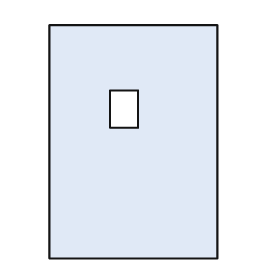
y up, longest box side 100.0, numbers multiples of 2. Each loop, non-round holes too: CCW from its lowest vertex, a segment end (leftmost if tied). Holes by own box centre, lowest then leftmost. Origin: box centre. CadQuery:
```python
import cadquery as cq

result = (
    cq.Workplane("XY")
    .moveTo(-36.0, -50.0)
    .lineTo(36.0, -50.0)
    .lineTo(36.0, 50.0)
    .lineTo(-36.0, 50.0)
    .close()
    .moveTo(-10.0, 6.0)
    .lineTo(2.0, 6.0)
    .lineTo(2.0, 22.0)
    .lineTo(-10.0, 22.0)
    .close()
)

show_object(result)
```